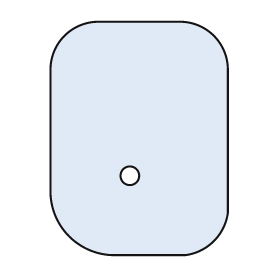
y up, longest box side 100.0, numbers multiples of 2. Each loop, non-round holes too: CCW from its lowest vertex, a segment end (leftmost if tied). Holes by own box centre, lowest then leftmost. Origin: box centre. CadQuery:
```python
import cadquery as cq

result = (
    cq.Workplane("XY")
    .moveTo(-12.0, -50.0)
    .lineTo(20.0, -50.0)
    .threePointArc((32.0, -44.0), (38.0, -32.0))
    .lineTo(38.0, 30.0)
    .threePointArc((32.0, 44.0), (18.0, 50.0))
    .lineTo(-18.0, 50.0)
    .threePointArc((-32.0, 44.0), (-38.0, 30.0))
    .lineTo(-38.0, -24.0)
    .threePointArc((-30.0, -42.0), (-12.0, -50.0))
    .close()
    .moveTo(-4.0, -16.0)
    .circle(4.0)
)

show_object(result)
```